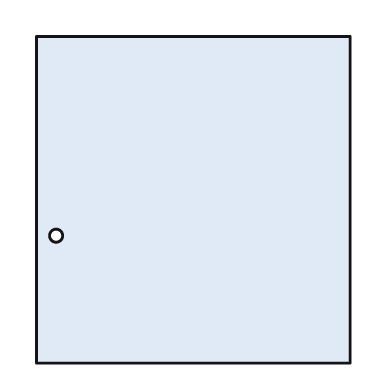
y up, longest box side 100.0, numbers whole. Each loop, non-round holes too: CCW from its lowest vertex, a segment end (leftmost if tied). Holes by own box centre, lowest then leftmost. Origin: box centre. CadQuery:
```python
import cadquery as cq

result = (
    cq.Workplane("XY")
    .moveTo(-48.0, -50.0)
    .lineTo(48.0, -50.0)
    .lineTo(48.0, 50.0)
    .lineTo(-48.0, 50.0)
    .close()
    .moveTo(-42.0, -11.0)
    .circle(2.0)
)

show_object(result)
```